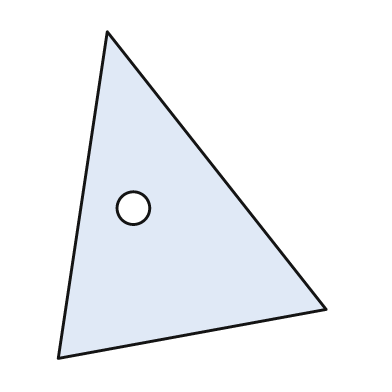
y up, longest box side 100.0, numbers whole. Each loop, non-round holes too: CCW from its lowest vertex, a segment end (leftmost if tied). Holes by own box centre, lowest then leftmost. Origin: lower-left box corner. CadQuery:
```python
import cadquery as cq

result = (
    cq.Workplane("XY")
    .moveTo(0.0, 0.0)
    .lineTo(82.0, 15.0)
    .lineTo(15.0, 100.0)
    .close()
    .moveTo(23.0, 46.0)
    .circle(5.0)
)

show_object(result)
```